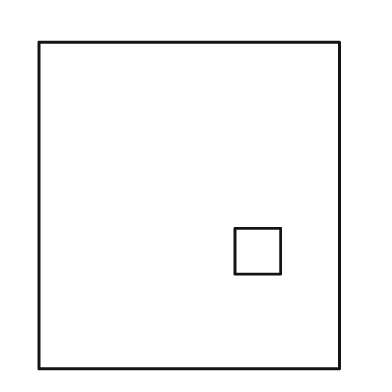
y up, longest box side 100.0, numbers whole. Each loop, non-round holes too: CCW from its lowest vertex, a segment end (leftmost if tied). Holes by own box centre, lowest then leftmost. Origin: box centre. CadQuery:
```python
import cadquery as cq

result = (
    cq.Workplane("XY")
    .moveTo(-46.0, -50.0)
    .lineTo(46.0, -50.0)
    .lineTo(46.0, 50.0)
    .lineTo(-46.0, 50.0)
    .close()
    .moveTo(14.0, -21.0)
    .lineTo(28.0, -21.0)
    .lineTo(28.0, -7.0)
    .lineTo(14.0, -7.0)
    .close()
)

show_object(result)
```